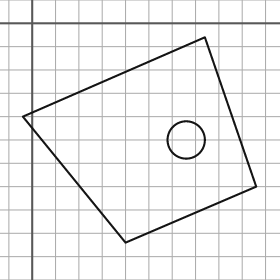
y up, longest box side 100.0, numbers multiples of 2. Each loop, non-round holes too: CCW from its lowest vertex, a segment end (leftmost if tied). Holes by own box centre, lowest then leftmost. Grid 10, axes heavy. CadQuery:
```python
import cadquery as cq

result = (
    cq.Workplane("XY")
    .moveTo(40.0, -94.0)
    .lineTo(96.0, -70.0)
    .lineTo(74.0, -6.0)
    .lineTo(-4.0, -40.0)
    .close()
    .moveTo(66.0, -50.0)
    .circle(8.0)
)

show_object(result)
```